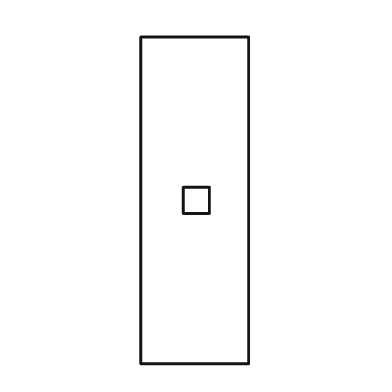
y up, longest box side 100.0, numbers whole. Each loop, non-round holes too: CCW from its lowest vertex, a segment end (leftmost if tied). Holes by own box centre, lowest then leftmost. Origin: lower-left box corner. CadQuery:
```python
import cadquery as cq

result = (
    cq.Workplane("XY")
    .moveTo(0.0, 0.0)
    .lineTo(33.0, 0.0)
    .lineTo(33.0, 100.0)
    .lineTo(0.0, 100.0)
    .close()
    .moveTo(13.0, 46.0)
    .lineTo(21.0, 46.0)
    .lineTo(21.0, 54.0)
    .lineTo(13.0, 54.0)
    .close()
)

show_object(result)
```